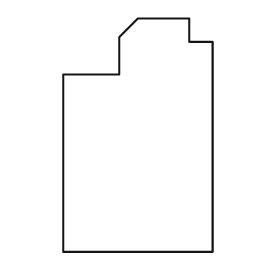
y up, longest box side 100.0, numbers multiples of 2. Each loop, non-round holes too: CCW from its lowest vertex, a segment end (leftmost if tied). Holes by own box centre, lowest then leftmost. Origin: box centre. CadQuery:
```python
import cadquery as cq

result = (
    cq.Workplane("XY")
    .moveTo(-32.0, -50.0)
    .lineTo(32.0, -50.0)
    .lineTo(32.0, 40.0)
    .lineTo(22.0, 40.0)
    .lineTo(22.0, 50.0)
    .lineTo(0.0, 50.0)
    .lineTo(-8.0, 42.0)
    .lineTo(-8.0, 26.0)
    .lineTo(-32.0, 26.0)
    .close()
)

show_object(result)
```